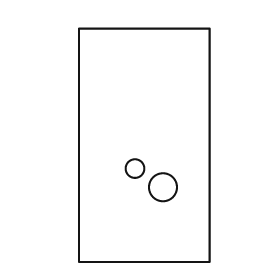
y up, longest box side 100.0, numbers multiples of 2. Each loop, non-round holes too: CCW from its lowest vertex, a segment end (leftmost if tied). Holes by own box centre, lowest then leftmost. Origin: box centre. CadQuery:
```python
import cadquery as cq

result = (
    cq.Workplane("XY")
    .moveTo(-28.0, -50.0)
    .lineTo(28.0, -50.0)
    .lineTo(28.0, 50.0)
    .lineTo(-28.0, 50.0)
    .close()
    .moveTo(8.0, -18.0)
    .circle(6.0)
    .moveTo(-4.0, -10.0)
    .circle(4.0)
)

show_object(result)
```